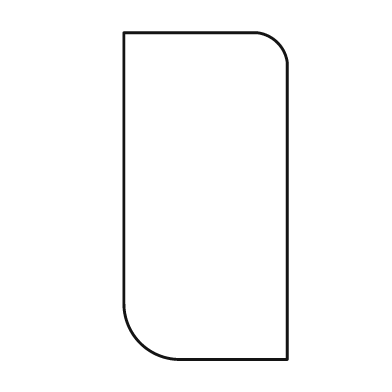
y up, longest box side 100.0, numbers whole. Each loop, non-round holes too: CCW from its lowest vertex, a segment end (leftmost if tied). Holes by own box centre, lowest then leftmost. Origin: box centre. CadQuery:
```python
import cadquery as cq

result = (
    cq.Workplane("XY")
    .moveTo(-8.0, -50.0)
    .lineTo(25.0, -50.0)
    .lineTo(25.0, 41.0)
    .threePointArc((22.0, 47.0), (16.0, 50.0))
    .lineTo(-25.0, 50.0)
    .lineTo(-25.0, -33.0)
    .threePointArc((-20.0, -45.0), (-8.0, -50.0))
    .close()
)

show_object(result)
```